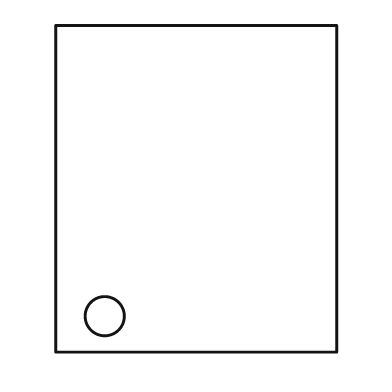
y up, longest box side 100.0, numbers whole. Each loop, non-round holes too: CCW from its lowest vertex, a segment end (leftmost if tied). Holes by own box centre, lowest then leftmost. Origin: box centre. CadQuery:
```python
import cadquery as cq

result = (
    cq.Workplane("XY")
    .moveTo(-43.0, -50.0)
    .lineTo(43.0, -50.0)
    .lineTo(43.0, 50.0)
    .lineTo(-43.0, 50.0)
    .close()
    .moveTo(-28.0, -39.0)
    .circle(6.0)
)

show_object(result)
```